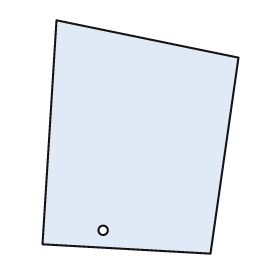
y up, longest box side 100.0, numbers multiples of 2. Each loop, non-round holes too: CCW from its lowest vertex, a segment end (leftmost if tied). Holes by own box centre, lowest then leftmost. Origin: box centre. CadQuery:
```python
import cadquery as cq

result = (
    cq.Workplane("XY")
    .moveTo(30.0, -50.0)
    .lineTo(42.0, 34.0)
    .lineTo(-36.0, 50.0)
    .lineTo(-42.0, -46.0)
    .close()
    .moveTo(-16.0, -40.0)
    .circle(2.0)
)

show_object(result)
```